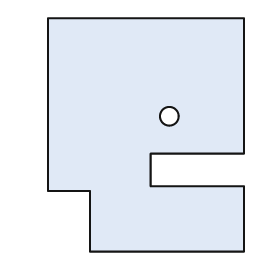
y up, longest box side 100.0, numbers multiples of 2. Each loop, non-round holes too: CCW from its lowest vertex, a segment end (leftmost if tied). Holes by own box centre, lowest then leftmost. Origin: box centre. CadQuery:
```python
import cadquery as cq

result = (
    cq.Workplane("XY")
    .moveTo(-24.0, -50.0)
    .lineTo(42.0, -50.0)
    .lineTo(42.0, -22.0)
    .lineTo(2.0, -22.0)
    .lineTo(2.0, -8.0)
    .lineTo(42.0, -8.0)
    .lineTo(42.0, 50.0)
    .lineTo(-42.0, 50.0)
    .lineTo(-42.0, -24.0)
    .lineTo(-24.0, -24.0)
    .close()
    .moveTo(10.0, 8.0)
    .circle(4.0)
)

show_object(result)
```